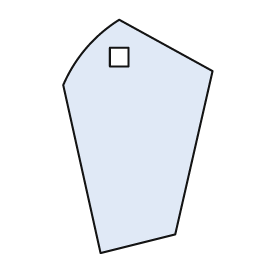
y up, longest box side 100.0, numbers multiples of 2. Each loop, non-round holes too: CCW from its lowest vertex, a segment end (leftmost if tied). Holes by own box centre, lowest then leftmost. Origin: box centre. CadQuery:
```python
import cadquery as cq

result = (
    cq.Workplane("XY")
    .moveTo(-16.0, -50.0)
    .lineTo(16.0, -42.0)
    .lineTo(32.0, 28.0)
    .lineTo(-8.0, 50.0)
    .threePointArc((-22.0, 38.0), (-32.0, 22.0))
    .close()
    .moveTo(-12.0, 30.0)
    .lineTo(-4.0, 30.0)
    .lineTo(-4.0, 38.0)
    .lineTo(-12.0, 38.0)
    .close()
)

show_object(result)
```